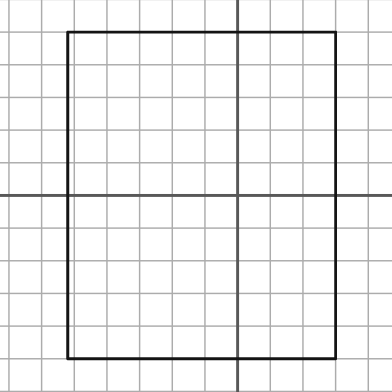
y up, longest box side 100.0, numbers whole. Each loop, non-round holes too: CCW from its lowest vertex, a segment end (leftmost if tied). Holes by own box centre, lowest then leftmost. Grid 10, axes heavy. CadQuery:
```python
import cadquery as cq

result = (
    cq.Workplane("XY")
    .moveTo(-52.0, -50.0)
    .lineTo(30.0, -50.0)
    .lineTo(30.0, 50.0)
    .lineTo(-52.0, 50.0)
    .close()
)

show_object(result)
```